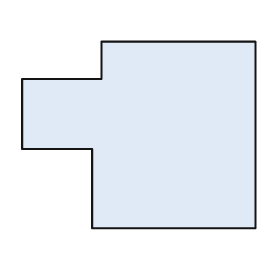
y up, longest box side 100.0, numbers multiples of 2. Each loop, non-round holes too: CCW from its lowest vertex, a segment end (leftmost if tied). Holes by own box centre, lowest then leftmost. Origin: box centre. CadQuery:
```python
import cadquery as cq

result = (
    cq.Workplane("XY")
    .moveTo(-20.0, -40.0)
    .lineTo(50.0, -40.0)
    .lineTo(50.0, 40.0)
    .lineTo(-16.0, 40.0)
    .lineTo(-16.0, 24.0)
    .lineTo(-50.0, 24.0)
    .lineTo(-50.0, -6.0)
    .lineTo(-20.0, -6.0)
    .close()
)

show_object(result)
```